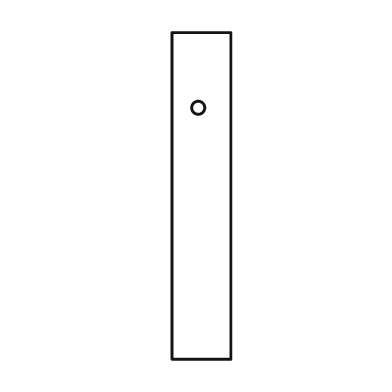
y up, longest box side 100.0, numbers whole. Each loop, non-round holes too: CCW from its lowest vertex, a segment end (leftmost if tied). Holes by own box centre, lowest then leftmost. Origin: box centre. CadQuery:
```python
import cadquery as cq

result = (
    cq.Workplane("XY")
    .moveTo(-9.0, -50.0)
    .lineTo(9.0, -50.0)
    .lineTo(9.0, 50.0)
    .lineTo(-9.0, 50.0)
    .close()
    .moveTo(-1.0, 27.0)
    .circle(2.0)
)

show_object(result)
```